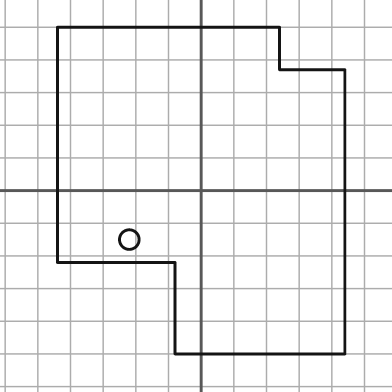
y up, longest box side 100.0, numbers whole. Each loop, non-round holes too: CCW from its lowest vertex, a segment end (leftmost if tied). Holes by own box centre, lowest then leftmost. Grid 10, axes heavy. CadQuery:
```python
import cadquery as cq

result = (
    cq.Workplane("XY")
    .moveTo(-8.0, -50.0)
    .lineTo(44.0, -50.0)
    .lineTo(44.0, 37.0)
    .lineTo(24.0, 37.0)
    .lineTo(24.0, 50.0)
    .lineTo(-44.0, 50.0)
    .lineTo(-44.0, -22.0)
    .lineTo(-8.0, -22.0)
    .close()
    .moveTo(-22.0, -15.0)
    .circle(3.0)
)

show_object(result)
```